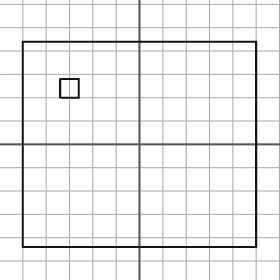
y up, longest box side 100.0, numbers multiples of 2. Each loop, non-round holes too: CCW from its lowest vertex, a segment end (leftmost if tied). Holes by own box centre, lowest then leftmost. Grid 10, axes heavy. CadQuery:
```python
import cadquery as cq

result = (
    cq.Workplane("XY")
    .moveTo(-50.0, -44.0)
    .lineTo(50.0, -44.0)
    .lineTo(50.0, 44.0)
    .lineTo(-50.0, 44.0)
    .close()
    .moveTo(-34.0, 20.0)
    .lineTo(-26.0, 20.0)
    .lineTo(-26.0, 28.0)
    .lineTo(-34.0, 28.0)
    .close()
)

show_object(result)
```